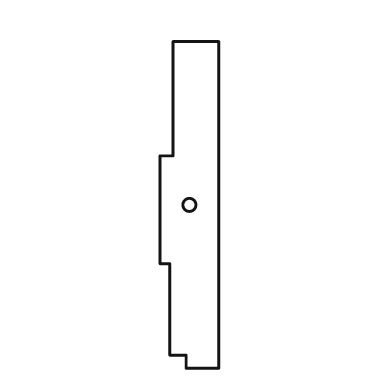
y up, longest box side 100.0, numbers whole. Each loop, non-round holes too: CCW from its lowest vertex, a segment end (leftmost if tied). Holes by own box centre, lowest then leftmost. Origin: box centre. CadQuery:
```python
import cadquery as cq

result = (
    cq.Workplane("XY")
    .moveTo(-1.0, -50.0)
    .lineTo(9.0, -50.0)
    .lineTo(9.0, 50.0)
    .lineTo(-5.0, 50.0)
    .lineTo(-5.0, 15.0)
    .lineTo(-9.0, 15.0)
    .lineTo(-9.0, -18.0)
    .lineTo(-6.0, -18.0)
    .lineTo(-6.0, -46.0)
    .lineTo(-1.0, -46.0)
    .close()
    .moveTo(0.0, 0.0)
    .circle(2.0)
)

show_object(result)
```